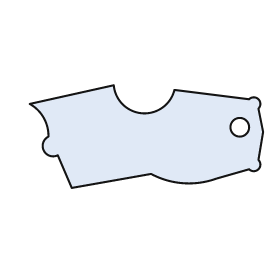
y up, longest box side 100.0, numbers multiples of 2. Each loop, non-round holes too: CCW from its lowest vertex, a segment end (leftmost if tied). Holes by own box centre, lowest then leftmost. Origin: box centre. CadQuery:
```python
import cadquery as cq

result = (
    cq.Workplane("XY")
    .moveTo(-32.0, -22.0)
    .lineTo(2.0, -16.0)
    .threePointArc((16.0, -20.0), (30.0, -18.0))
    .lineTo(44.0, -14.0)
    .threePointArc((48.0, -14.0), (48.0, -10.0))
    .lineTo(50.0, 2.0)
    .lineTo(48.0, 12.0)
    .threePointArc((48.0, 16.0), (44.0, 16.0))
    .lineTo(12.0, 20.0)
    .threePointArc((-2.0, 10.0), (-14.0, 22.0))
    .lineTo(-50.0, 14.0)
    .threePointArc((-44.0, 8.0), (-42.0, 0.0))
    .threePointArc((-44.0, -6.0), (-38.0, -8.0))
    .close()
    .moveTo(40.0, 4.0)
    .circle(4.0)
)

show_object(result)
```